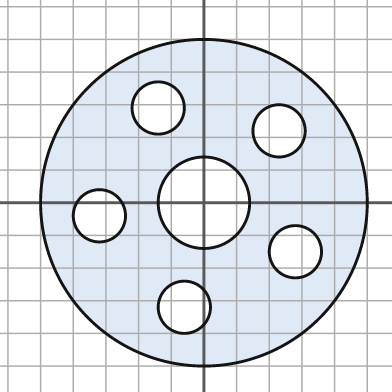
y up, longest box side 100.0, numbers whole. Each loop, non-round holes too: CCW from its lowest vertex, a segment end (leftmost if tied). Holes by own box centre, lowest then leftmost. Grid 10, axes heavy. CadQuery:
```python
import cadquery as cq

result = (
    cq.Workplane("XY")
    .moveTo(0.0, 0.0)
    .circle(50.0)
    .moveTo(-6.0, -32.0)
    .circle(8.0)
    .moveTo(28.0, -15.0)
    .circle(8.0)
    .moveTo(-32.0, -4.0)
    .circle(8.0)
    .moveTo(0.0, 0.0)
    .circle(14.0)
    .moveTo(23.0, 22.0)
    .circle(8.0)
    .moveTo(-14.0, 29.0)
    .circle(8.0)
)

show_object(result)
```